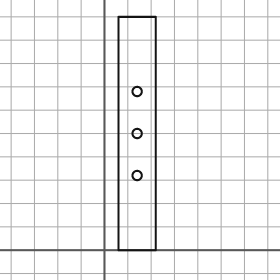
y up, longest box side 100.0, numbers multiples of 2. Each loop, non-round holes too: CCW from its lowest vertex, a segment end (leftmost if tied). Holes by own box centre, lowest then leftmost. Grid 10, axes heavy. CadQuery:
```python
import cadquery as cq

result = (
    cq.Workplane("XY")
    .moveTo(6.0, 0.0)
    .lineTo(22.0, 0.0)
    .lineTo(22.0, 100.0)
    .lineTo(6.0, 100.0)
    .close()
    .moveTo(14.0, 32.0)
    .circle(2.0)
    .moveTo(14.0, 50.0)
    .circle(2.0)
    .moveTo(14.0, 68.0)
    .circle(2.0)
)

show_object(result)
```